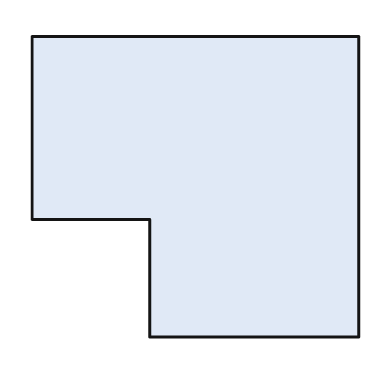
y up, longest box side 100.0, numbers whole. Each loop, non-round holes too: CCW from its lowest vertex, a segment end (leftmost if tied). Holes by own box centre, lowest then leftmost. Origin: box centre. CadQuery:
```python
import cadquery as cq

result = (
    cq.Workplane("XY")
    .moveTo(-14.0, -46.0)
    .lineTo(50.0, -46.0)
    .lineTo(50.0, 46.0)
    .lineTo(-50.0, 46.0)
    .lineTo(-50.0, -10.0)
    .lineTo(-14.0, -10.0)
    .close()
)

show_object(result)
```